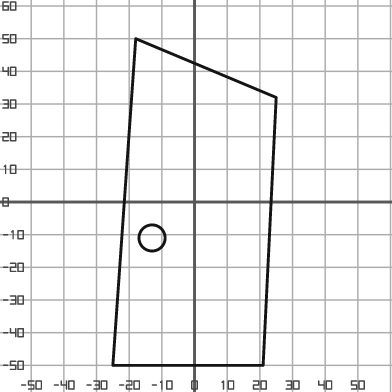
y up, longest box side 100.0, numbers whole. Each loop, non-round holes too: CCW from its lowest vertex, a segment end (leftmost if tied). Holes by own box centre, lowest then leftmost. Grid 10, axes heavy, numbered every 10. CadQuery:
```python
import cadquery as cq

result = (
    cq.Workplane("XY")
    .moveTo(-25.0, -50.0)
    .lineTo(21.0, -50.0)
    .lineTo(25.0, 32.0)
    .lineTo(-18.0, 50.0)
    .close()
    .moveTo(-13.0, -11.0)
    .circle(4.0)
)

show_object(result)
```